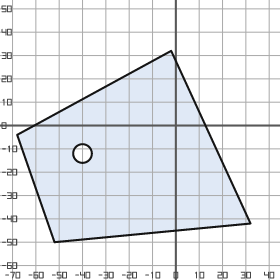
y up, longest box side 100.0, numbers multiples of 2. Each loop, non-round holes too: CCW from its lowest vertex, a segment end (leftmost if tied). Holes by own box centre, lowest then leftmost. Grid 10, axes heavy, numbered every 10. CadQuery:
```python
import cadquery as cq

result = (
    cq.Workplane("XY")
    .moveTo(-52.0, -50.0)
    .lineTo(32.0, -42.0)
    .lineTo(-2.0, 32.0)
    .lineTo(-68.0, -4.0)
    .close()
    .moveTo(-40.0, -12.0)
    .circle(4.0)
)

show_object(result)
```